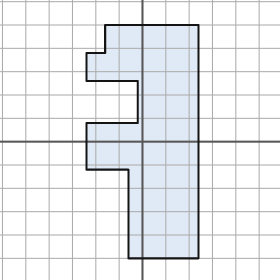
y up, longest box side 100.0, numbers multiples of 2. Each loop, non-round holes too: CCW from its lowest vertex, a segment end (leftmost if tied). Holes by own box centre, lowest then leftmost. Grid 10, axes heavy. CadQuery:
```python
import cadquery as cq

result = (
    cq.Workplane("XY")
    .moveTo(-6.0, -50.0)
    .lineTo(24.0, -50.0)
    .lineTo(24.0, 50.0)
    .lineTo(-16.0, 50.0)
    .lineTo(-16.0, 38.0)
    .lineTo(-24.0, 38.0)
    .lineTo(-24.0, 26.0)
    .lineTo(-2.0, 26.0)
    .lineTo(-2.0, 8.0)
    .lineTo(-24.0, 8.0)
    .lineTo(-24.0, -12.0)
    .lineTo(-6.0, -12.0)
    .close()
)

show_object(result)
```